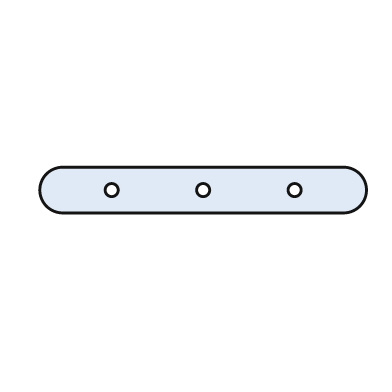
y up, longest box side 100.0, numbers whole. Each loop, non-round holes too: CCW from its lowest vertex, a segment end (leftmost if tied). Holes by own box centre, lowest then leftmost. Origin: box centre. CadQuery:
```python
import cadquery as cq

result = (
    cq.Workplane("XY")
    .moveTo(-43.0, -7.0)
    .lineTo(43.0, -7.0)
    .threePointArc((50.0, 0.0), (43.0, 7.0))
    .lineTo(-43.0, 7.0)
    .threePointArc((-50.0, 0.0), (-43.0, -7.0))
    .close()
    .moveTo(-28.0, 0.0)
    .circle(2.0)
    .moveTo(0.0, 0.0)
    .circle(2.0)
    .moveTo(28.0, 0.0)
    .circle(2.0)
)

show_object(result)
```